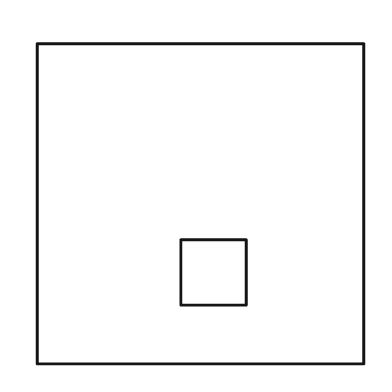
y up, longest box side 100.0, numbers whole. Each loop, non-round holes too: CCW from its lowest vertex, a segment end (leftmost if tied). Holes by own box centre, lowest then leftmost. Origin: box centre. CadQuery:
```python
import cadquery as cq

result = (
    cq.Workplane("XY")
    .moveTo(-50.0, -49.0)
    .lineTo(50.0, -49.0)
    .lineTo(50.0, 49.0)
    .lineTo(-50.0, 49.0)
    .close()
    .moveTo(-6.0, -31.0)
    .lineTo(14.0, -31.0)
    .lineTo(14.0, -11.0)
    .lineTo(-6.0, -11.0)
    .close()
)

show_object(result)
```